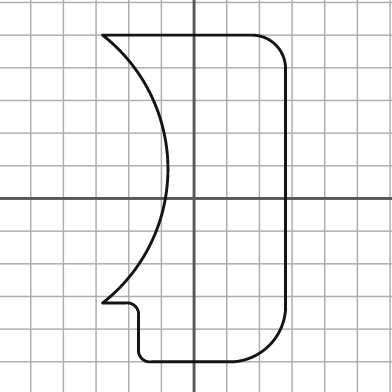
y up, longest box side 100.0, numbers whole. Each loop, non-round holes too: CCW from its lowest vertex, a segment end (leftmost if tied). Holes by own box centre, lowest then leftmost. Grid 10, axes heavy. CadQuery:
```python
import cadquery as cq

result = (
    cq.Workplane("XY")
    .moveTo(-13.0, -50.0)
    .lineTo(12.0, -50.0)
    .threePointArc((23.0, -45.0), (28.0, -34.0))
    .lineTo(28.0, 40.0)
    .threePointArc((25.0, 47.0), (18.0, 50.0))
    .lineTo(-28.0, 50.0)
    .threePointArc((-8.0, 9.0), (-28.0, -32.0))
    .lineTo(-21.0, -32.0)
    .threePointArc((-18.0, -33.0), (-17.0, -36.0))
    .lineTo(-17.0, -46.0)
    .threePointArc((-16.0, -49.0), (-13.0, -50.0))
    .close()
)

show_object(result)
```